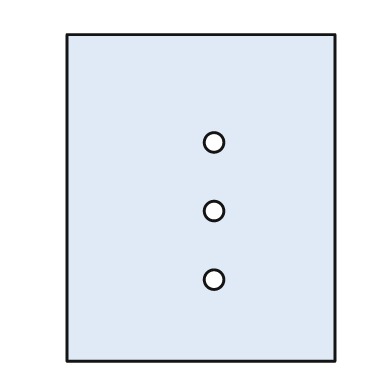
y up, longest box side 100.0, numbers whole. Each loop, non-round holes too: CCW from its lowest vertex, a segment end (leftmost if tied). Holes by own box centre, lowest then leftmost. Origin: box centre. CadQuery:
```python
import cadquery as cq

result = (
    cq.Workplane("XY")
    .moveTo(-41.0, -50.0)
    .lineTo(41.0, -50.0)
    .lineTo(41.0, 50.0)
    .lineTo(-41.0, 50.0)
    .close()
    .moveTo(4.0, -25.0)
    .circle(3.0)
    .moveTo(4.0, -4.0)
    .circle(3.0)
    .moveTo(4.0, 17.0)
    .circle(3.0)
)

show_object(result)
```